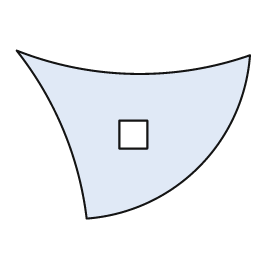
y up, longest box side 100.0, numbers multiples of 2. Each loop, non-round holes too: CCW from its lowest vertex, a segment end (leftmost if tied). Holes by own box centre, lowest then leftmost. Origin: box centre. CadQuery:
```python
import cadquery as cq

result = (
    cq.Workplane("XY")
    .moveTo(-20.0, -36.0)
    .threePointArc((28.0, -14.0), (50.0, 34.0))
    .threePointArc((0.0, 26.0), (-50.0, 36.0))
    .threePointArc((-30.0, 2.0), (-20.0, -36.0))
    .close()
    .moveTo(-6.0, -6.0)
    .lineTo(6.0, -6.0)
    .lineTo(6.0, 6.0)
    .lineTo(-6.0, 6.0)
    .close()
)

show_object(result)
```